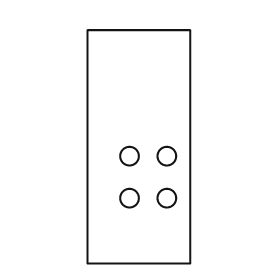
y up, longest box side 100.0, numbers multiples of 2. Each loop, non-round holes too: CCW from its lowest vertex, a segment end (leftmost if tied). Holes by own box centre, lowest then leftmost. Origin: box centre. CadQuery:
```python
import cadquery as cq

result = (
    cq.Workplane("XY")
    .moveTo(-22.0, -50.0)
    .lineTo(22.0, -50.0)
    .lineTo(22.0, 50.0)
    .lineTo(-22.0, 50.0)
    .close()
    .moveTo(-4.0, -22.0)
    .circle(4.0)
    .moveTo(12.0, -22.0)
    .circle(4.0)
    .moveTo(-4.0, -4.0)
    .circle(4.0)
    .moveTo(12.0, -4.0)
    .circle(4.0)
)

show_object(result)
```